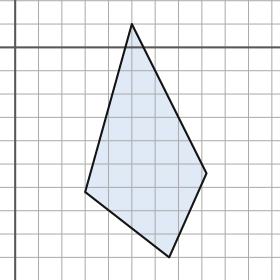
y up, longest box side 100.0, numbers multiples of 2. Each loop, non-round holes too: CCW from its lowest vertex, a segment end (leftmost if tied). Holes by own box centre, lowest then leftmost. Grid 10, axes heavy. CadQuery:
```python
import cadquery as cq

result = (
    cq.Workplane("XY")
    .moveTo(66.0, -90.0)
    .lineTo(82.0, -54.0)
    .lineTo(50.0, 10.0)
    .lineTo(30.0, -62.0)
    .close()
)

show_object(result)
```